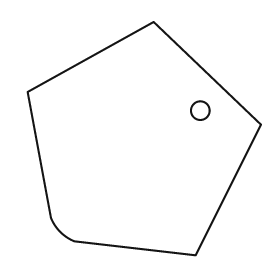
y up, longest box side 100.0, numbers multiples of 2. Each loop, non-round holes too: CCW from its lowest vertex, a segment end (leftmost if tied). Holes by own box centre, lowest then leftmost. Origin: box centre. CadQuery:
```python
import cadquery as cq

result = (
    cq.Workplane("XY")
    .moveTo(22.0, -50.0)
    .lineTo(50.0, 6.0)
    .lineTo(4.0, 50.0)
    .lineTo(-50.0, 20.0)
    .lineTo(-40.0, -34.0)
    .threePointArc((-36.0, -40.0), (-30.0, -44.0))
    .close()
    .moveTo(24.0, 12.0)
    .circle(4.0)
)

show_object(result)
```